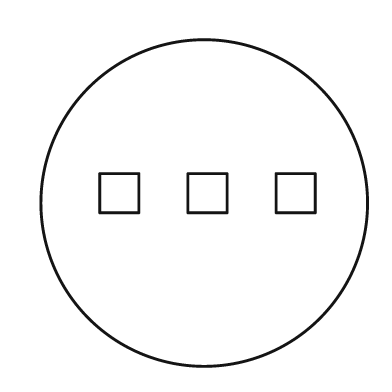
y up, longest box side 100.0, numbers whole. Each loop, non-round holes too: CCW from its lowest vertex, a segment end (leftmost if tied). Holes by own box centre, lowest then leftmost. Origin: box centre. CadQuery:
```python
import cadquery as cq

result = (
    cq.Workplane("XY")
    .moveTo(0.0, 0.0)
    .circle(50.0)
    .moveTo(-32.0, -3.0)
    .lineTo(-20.0, -3.0)
    .lineTo(-20.0, 9.0)
    .lineTo(-32.0, 9.0)
    .close()
    .moveTo(-5.0, -3.0)
    .lineTo(7.0, -3.0)
    .lineTo(7.0, 9.0)
    .lineTo(-5.0, 9.0)
    .close()
    .moveTo(22.0, -3.0)
    .lineTo(34.0, -3.0)
    .lineTo(34.0, 9.0)
    .lineTo(22.0, 9.0)
    .close()
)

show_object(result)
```